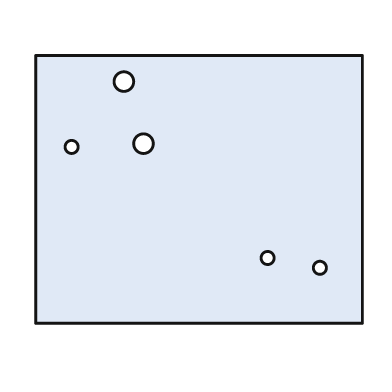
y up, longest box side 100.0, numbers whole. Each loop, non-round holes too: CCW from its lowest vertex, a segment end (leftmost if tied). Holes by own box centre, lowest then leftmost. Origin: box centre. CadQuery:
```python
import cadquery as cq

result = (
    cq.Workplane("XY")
    .moveTo(-50.0, -41.0)
    .lineTo(50.0, -41.0)
    .lineTo(50.0, 41.0)
    .lineTo(-50.0, 41.0)
    .close()
    .moveTo(37.0, -24.0)
    .circle(2.0)
    .moveTo(21.0, -21.0)
    .circle(2.0)
    .moveTo(-39.0, 13.0)
    .circle(2.0)
    .moveTo(-17.0, 14.0)
    .circle(3.0)
    .moveTo(-23.0, 33.0)
    .circle(3.0)
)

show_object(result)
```